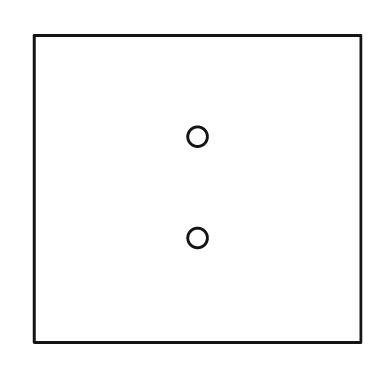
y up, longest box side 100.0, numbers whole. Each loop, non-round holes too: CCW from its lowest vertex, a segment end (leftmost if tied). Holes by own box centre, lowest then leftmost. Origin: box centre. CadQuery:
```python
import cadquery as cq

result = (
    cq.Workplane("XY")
    .moveTo(-50.0, -47.0)
    .lineTo(50.0, -47.0)
    .lineTo(50.0, 47.0)
    .lineTo(-50.0, 47.0)
    .close()
    .moveTo(0.0, -15.0)
    .circle(3.0)
    .moveTo(0.0, 16.0)
    .circle(3.0)
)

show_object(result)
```